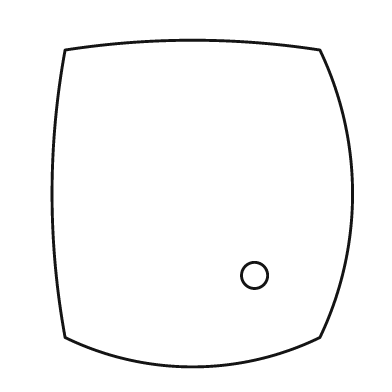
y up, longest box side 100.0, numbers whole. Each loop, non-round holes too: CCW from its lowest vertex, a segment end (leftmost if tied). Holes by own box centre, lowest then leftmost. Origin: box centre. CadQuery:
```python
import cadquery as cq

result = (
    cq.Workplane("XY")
    .moveTo(-42.0, -41.0)
    .threePointArc((-3.0, -50.0), (36.0, -41.0))
    .threePointArc((46.0, 3.0), (36.0, 47.0))
    .threePointArc((-3.0, 50.0), (-42.0, 47.0))
    .threePointArc((-46.0, 3.0), (-42.0, -41.0))
    .close()
    .moveTo(16.0, -22.0)
    .circle(4.0)
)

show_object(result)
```